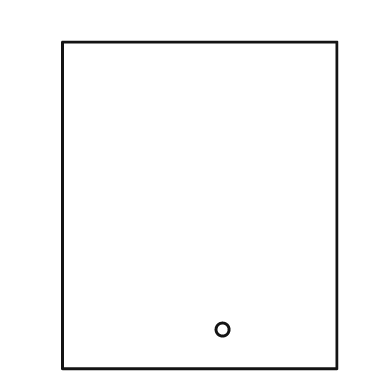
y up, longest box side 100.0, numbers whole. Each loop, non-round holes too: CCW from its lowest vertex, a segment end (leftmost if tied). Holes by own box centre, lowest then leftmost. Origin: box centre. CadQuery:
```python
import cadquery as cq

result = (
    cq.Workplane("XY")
    .moveTo(-42.0, -50.0)
    .lineTo(42.0, -50.0)
    .lineTo(42.0, 50.0)
    .lineTo(-42.0, 50.0)
    .close()
    .moveTo(7.0, -38.0)
    .circle(2.0)
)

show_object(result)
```